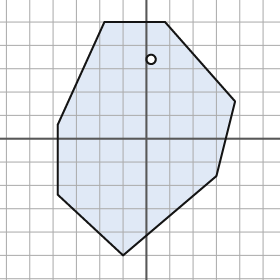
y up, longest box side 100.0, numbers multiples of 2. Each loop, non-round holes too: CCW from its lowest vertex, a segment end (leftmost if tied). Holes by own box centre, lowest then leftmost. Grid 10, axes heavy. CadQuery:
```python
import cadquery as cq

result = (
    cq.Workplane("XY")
    .moveTo(-10.0, -50.0)
    .lineTo(30.0, -16.0)
    .lineTo(38.0, 16.0)
    .lineTo(8.0, 50.0)
    .lineTo(-18.0, 50.0)
    .lineTo(-38.0, 6.0)
    .lineTo(-38.0, -24.0)
    .close()
    .moveTo(2.0, 34.0)
    .circle(2.0)
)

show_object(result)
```